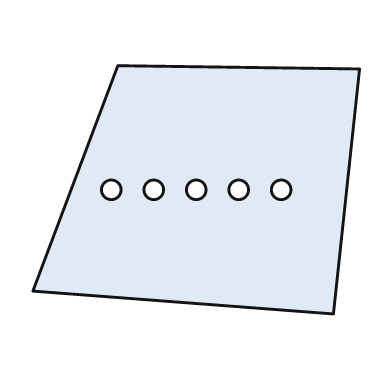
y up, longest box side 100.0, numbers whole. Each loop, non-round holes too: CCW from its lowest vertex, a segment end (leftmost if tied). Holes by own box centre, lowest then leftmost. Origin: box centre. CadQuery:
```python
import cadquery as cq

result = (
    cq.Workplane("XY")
    .moveTo(42.0, -38.0)
    .lineTo(50.0, 37.0)
    .lineTo(-24.0, 38.0)
    .lineTo(-50.0, -31.0)
    .close()
    .moveTo(-26.0, 0.0)
    .circle(3.0)
    .moveTo(-13.0, 0.0)
    .circle(3.0)
    .moveTo(0.0, 0.0)
    .circle(3.0)
    .moveTo(13.0, 0.0)
    .circle(3.0)
    .moveTo(26.0, 0.0)
    .circle(3.0)
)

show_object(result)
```